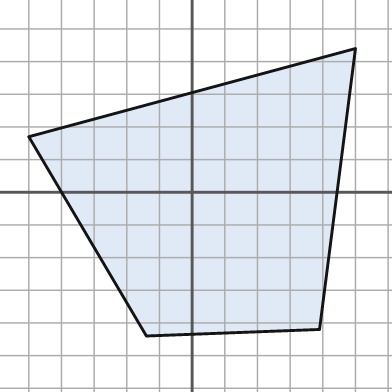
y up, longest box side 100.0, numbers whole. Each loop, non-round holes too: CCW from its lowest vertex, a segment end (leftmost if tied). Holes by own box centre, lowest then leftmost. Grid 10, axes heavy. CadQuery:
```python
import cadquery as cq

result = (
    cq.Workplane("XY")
    .moveTo(-14.0, -44.0)
    .lineTo(39.0, -42.0)
    .lineTo(50.0, 44.0)
    .lineTo(-50.0, 17.0)
    .close()
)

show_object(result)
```